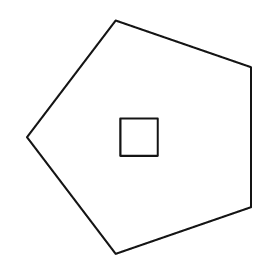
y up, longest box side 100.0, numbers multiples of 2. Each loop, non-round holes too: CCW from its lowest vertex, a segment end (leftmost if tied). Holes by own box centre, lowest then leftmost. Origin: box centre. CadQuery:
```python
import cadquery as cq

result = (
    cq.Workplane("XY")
    .moveTo(-10.0, -50.0)
    .lineTo(48.0, -30.0)
    .lineTo(48.0, 30.0)
    .lineTo(-10.0, 50.0)
    .lineTo(-48.0, 0.0)
    .close()
    .moveTo(-8.0, -8.0)
    .lineTo(8.0, -8.0)
    .lineTo(8.0, 8.0)
    .lineTo(-8.0, 8.0)
    .close()
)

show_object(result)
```